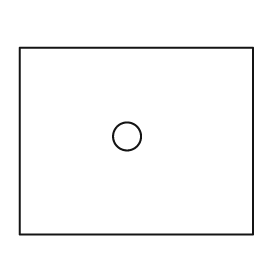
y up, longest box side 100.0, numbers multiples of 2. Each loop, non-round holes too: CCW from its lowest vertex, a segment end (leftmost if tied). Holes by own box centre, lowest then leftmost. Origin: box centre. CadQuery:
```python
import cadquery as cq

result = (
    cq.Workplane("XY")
    .moveTo(-50.0, -40.0)
    .lineTo(50.0, -40.0)
    .lineTo(50.0, 40.0)
    .lineTo(-50.0, 40.0)
    .close()
    .moveTo(-4.0, 2.0)
    .circle(6.0)
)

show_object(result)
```